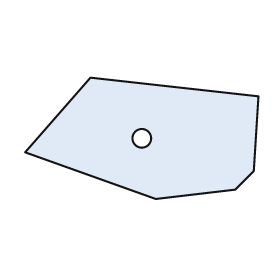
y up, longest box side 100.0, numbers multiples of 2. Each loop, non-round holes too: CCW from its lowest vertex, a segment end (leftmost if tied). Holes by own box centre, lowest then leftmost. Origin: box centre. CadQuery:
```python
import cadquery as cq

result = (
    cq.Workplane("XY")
    .moveTo(6.0, -26.0)
    .lineTo(40.0, -22.0)
    .lineTo(48.0, -14.0)
    .lineTo(50.0, 18.0)
    .lineTo(-22.0, 26.0)
    .lineTo(-50.0, -6.0)
    .close()
    .moveTo(0.0, 0.0)
    .circle(4.0)
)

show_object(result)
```